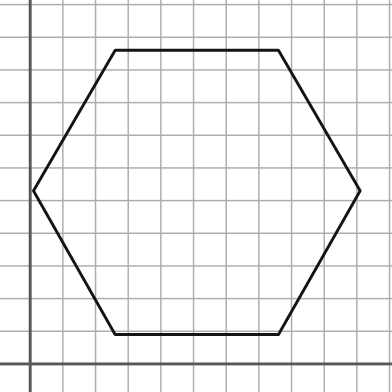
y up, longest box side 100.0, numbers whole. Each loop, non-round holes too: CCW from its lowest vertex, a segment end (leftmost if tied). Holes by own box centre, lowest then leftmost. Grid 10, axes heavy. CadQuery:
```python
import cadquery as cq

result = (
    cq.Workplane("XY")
    .moveTo(26.0, 9.0)
    .lineTo(76.0, 9.0)
    .lineTo(101.0, 53.0)
    .lineTo(76.0, 96.0)
    .lineTo(26.0, 96.0)
    .lineTo(1.0, 53.0)
    .close()
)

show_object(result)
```